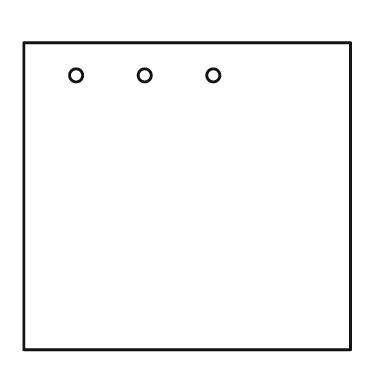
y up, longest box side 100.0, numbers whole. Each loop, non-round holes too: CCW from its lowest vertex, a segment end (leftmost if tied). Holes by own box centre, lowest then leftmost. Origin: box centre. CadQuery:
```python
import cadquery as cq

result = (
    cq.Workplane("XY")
    .moveTo(-50.0, -47.0)
    .lineTo(50.0, -47.0)
    .lineTo(50.0, 47.0)
    .lineTo(-50.0, 47.0)
    .close()
    .moveTo(-34.0, 37.0)
    .circle(2.0)
    .moveTo(-13.0, 37.0)
    .circle(2.0)
    .moveTo(8.0, 37.0)
    .circle(2.0)
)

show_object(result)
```